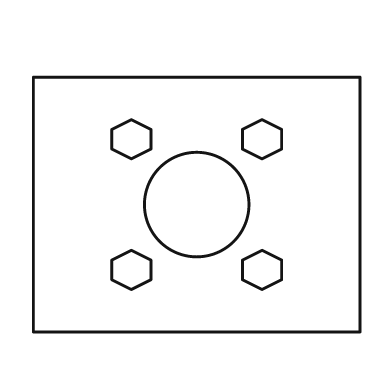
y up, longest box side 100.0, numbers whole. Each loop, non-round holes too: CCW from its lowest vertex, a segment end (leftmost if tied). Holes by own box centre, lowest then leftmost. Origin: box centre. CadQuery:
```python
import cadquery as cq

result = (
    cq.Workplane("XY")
    .moveTo(-50.0, -39.0)
    .lineTo(50.0, -39.0)
    .lineTo(50.0, 39.0)
    .lineTo(-50.0, 39.0)
    .close()
    .moveTo(-20.0, -26.0)
    .lineTo(-14.0, -23.0)
    .lineTo(-14.0, -17.0)
    .lineTo(-20.0, -14.0)
    .lineTo(-26.0, -17.0)
    .lineTo(-26.0, -23.0)
    .close()
    .moveTo(20.0, -26.0)
    .lineTo(26.0, -23.0)
    .lineTo(26.0, -17.0)
    .lineTo(20.0, -14.0)
    .lineTo(14.0, -17.0)
    .lineTo(14.0, -23.0)
    .close()
    .moveTo(0.0, 0.0)
    .circle(16.0)
    .moveTo(-20.0, 14.0)
    .lineTo(-14.0, 17.0)
    .lineTo(-14.0, 23.0)
    .lineTo(-20.0, 26.0)
    .lineTo(-26.0, 23.0)
    .lineTo(-26.0, 17.0)
    .close()
    .moveTo(20.0, 14.0)
    .lineTo(26.0, 17.0)
    .lineTo(26.0, 23.0)
    .lineTo(20.0, 26.0)
    .lineTo(14.0, 23.0)
    .lineTo(14.0, 17.0)
    .close()
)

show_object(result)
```